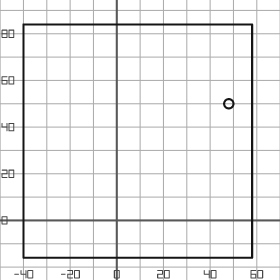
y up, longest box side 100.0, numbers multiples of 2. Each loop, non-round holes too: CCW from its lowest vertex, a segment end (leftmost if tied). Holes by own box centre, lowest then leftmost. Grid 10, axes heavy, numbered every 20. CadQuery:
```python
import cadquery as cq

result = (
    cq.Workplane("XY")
    .moveTo(-40.0, -16.0)
    .lineTo(58.0, -16.0)
    .lineTo(58.0, 84.0)
    .lineTo(-40.0, 84.0)
    .close()
    .moveTo(48.0, 50.0)
    .circle(2.0)
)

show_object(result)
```